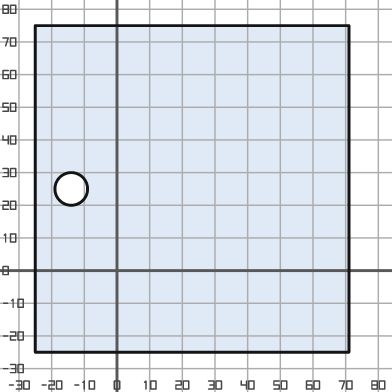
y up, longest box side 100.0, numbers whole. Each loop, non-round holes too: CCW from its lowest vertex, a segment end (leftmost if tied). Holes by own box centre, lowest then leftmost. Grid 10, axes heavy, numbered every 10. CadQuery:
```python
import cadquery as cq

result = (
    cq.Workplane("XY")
    .moveTo(-25.0, -25.0)
    .lineTo(71.0, -25.0)
    .lineTo(71.0, 75.0)
    .lineTo(-25.0, 75.0)
    .close()
    .moveTo(-14.0, 25.0)
    .circle(5.0)
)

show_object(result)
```